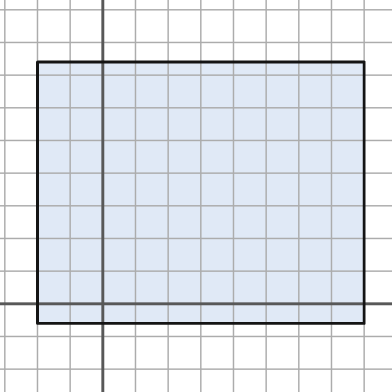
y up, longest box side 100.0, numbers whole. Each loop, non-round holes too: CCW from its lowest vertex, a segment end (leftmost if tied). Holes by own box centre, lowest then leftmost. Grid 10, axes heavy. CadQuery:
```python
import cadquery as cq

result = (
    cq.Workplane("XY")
    .moveTo(-20.0, -6.0)
    .lineTo(80.0, -6.0)
    .lineTo(80.0, 74.0)
    .lineTo(-20.0, 74.0)
    .close()
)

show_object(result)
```